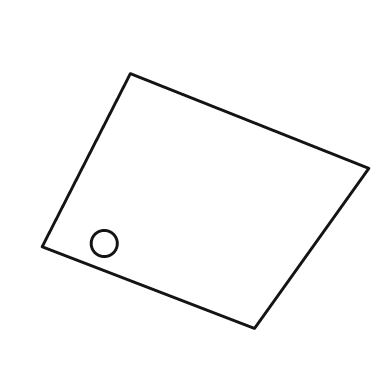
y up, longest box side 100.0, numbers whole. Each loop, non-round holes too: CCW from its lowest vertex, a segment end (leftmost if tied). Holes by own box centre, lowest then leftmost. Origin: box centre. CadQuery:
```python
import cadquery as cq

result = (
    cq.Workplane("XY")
    .moveTo(15.0, -39.0)
    .lineTo(50.0, 10.0)
    .lineTo(-23.0, 39.0)
    .lineTo(-50.0, -14.0)
    .close()
    .moveTo(-31.0, -13.0)
    .circle(4.0)
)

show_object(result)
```